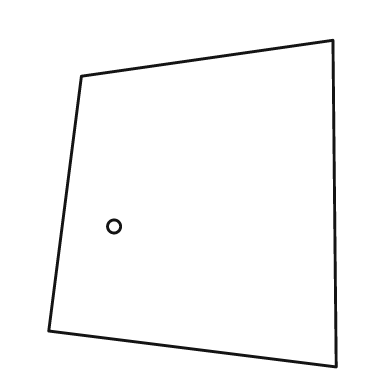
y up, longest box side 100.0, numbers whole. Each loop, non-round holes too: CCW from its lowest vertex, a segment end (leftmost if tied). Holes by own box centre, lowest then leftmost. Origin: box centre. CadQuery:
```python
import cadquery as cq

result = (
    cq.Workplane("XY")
    .moveTo(44.0, -50.0)
    .lineTo(43.0, 50.0)
    .lineTo(-34.0, 39.0)
    .lineTo(-44.0, -39.0)
    .close()
    .moveTo(-24.0, -7.0)
    .circle(2.0)
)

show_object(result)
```